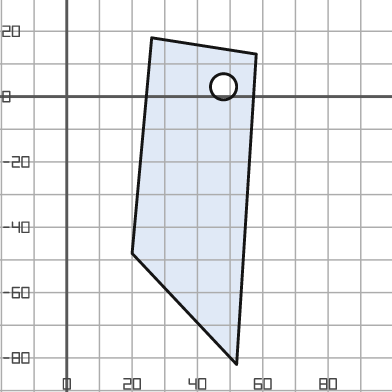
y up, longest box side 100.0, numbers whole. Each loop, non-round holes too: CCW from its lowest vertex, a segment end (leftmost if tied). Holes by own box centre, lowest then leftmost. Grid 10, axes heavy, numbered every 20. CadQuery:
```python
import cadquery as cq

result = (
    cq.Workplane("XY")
    .moveTo(52.0, -82.0)
    .lineTo(58.0, 13.0)
    .lineTo(26.0, 18.0)
    .lineTo(20.0, -48.0)
    .close()
    .moveTo(48.0, 3.0)
    .circle(4.0)
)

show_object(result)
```